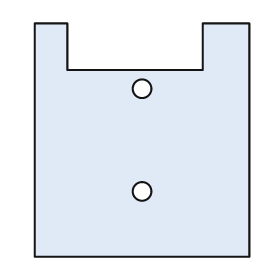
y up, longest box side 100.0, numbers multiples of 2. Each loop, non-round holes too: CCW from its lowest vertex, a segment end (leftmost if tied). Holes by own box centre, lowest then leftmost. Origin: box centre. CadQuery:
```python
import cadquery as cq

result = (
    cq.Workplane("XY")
    .moveTo(-46.0, -50.0)
    .lineTo(46.0, -50.0)
    .lineTo(46.0, 50.0)
    .lineTo(26.0, 50.0)
    .lineTo(26.0, 30.0)
    .lineTo(-32.0, 30.0)
    .lineTo(-32.0, 50.0)
    .lineTo(-46.0, 50.0)
    .close()
    .moveTo(0.0, -22.0)
    .circle(4.0)
    .moveTo(0.0, 22.0)
    .circle(4.0)
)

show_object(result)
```